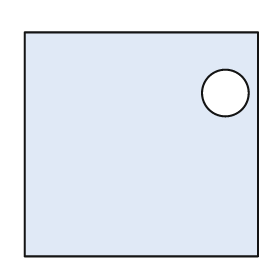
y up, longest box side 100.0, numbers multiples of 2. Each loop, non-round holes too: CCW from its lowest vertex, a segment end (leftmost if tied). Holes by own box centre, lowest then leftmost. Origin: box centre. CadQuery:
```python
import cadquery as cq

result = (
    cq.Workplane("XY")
    .moveTo(-50.0, -48.0)
    .lineTo(50.0, -48.0)
    .lineTo(50.0, 48.0)
    .lineTo(-50.0, 48.0)
    .close()
    .moveTo(36.0, 22.0)
    .circle(10.0)
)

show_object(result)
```